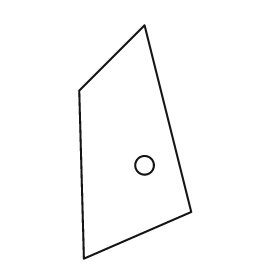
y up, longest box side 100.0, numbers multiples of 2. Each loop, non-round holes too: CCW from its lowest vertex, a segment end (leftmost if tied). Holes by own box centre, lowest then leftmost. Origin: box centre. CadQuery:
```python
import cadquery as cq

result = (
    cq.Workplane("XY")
    .moveTo(-22.0, -50.0)
    .lineTo(24.0, -30.0)
    .lineTo(4.0, 50.0)
    .lineTo(-24.0, 22.0)
    .close()
    .moveTo(4.0, -10.0)
    .circle(4.0)
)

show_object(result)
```